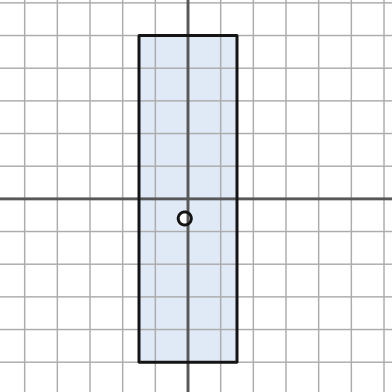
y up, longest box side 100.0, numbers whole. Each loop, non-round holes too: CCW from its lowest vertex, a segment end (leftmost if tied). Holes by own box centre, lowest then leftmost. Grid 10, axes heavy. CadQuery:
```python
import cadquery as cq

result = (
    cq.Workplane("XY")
    .moveTo(-15.0, -50.0)
    .lineTo(15.0, -50.0)
    .lineTo(15.0, 50.0)
    .lineTo(-15.0, 50.0)
    .close()
    .moveTo(-1.0, -6.0)
    .circle(2.0)
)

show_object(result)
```